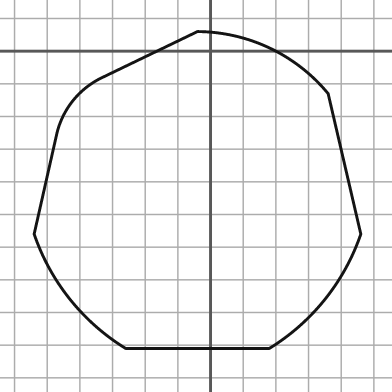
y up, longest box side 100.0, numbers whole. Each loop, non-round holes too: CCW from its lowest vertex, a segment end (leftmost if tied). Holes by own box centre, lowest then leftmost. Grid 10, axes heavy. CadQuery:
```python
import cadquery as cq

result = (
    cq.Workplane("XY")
    .moveTo(-26.0, -91.0)
    .lineTo(18.0, -91.0)
    .threePointArc((35.0, -76.0), (46.0, -56.0))
    .lineTo(36.0, -13.0)
    .threePointArc((18.0, 1.0), (-4.0, 6.0))
    .lineTo(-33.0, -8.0)
    .threePointArc((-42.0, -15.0), (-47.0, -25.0))
    .lineTo(-54.0, -56.0)
    .threePointArc((-43.0, -76.0), (-26.0, -91.0))
    .close()
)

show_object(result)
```